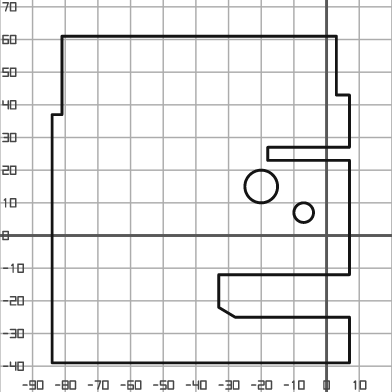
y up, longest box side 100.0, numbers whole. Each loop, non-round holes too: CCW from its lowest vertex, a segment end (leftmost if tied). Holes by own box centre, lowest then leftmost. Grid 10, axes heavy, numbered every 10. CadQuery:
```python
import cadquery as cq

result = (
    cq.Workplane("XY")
    .moveTo(-84.0, -39.0)
    .lineTo(7.0, -39.0)
    .lineTo(7.0, -25.0)
    .lineTo(-28.0, -25.0)
    .lineTo(-33.0, -22.0)
    .lineTo(-33.0, -12.0)
    .lineTo(7.0, -12.0)
    .lineTo(7.0, 23.0)
    .lineTo(-18.0, 23.0)
    .lineTo(-18.0, 27.0)
    .lineTo(7.0, 27.0)
    .lineTo(7.0, 43.0)
    .lineTo(3.0, 43.0)
    .lineTo(3.0, 61.0)
    .lineTo(-81.0, 61.0)
    .lineTo(-81.0, 37.0)
    .lineTo(-84.0, 37.0)
    .close()
    .moveTo(-7.0, 7.0)
    .circle(3.0)
    .moveTo(-20.0, 15.0)
    .circle(5.0)
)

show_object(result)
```